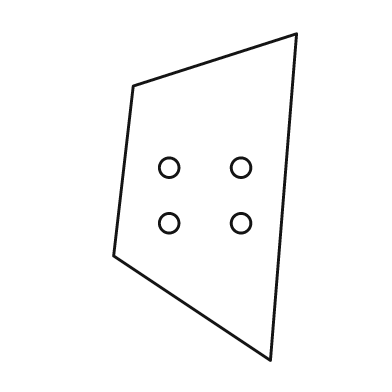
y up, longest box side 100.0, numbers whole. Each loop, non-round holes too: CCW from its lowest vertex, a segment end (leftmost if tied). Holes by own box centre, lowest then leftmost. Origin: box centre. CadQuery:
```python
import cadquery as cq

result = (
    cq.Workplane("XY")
    .moveTo(20.0, -50.0)
    .lineTo(28.0, 50.0)
    .lineTo(-22.0, 34.0)
    .lineTo(-28.0, -18.0)
    .close()
    .moveTo(-11.0, -8.0)
    .circle(3.0)
    .moveTo(11.0, -8.0)
    .circle(3.0)
    .moveTo(-11.0, 9.0)
    .circle(3.0)
    .moveTo(11.0, 9.0)
    .circle(3.0)
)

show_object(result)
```